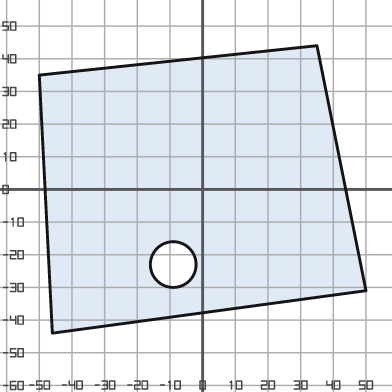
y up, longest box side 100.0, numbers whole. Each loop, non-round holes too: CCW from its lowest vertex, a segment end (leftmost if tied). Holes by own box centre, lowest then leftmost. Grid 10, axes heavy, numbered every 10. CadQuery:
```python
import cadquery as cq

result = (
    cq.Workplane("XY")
    .moveTo(-46.0, -44.0)
    .lineTo(50.0, -31.0)
    .lineTo(35.0, 44.0)
    .lineTo(-50.0, 35.0)
    .close()
    .moveTo(-9.0, -23.0)
    .circle(7.0)
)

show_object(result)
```